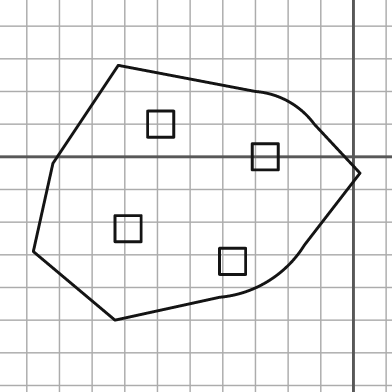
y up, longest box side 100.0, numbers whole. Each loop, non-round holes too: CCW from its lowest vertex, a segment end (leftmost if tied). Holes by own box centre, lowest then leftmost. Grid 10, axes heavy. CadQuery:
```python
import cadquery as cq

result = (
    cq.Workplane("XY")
    .moveTo(-73.0, -50.0)
    .lineTo(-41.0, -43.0)
    .threePointArc((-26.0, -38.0), (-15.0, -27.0))
    .lineTo(2.0, -5.0)
    .lineTo(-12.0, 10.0)
    .threePointArc((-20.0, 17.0), (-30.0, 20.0))
    .lineTo(-72.0, 28.0)
    .lineTo(-92.0, -2.0)
    .lineTo(-98.0, -29.0)
    .close()
    .moveTo(-41.0, -36.0)
    .lineTo(-33.0, -36.0)
    .lineTo(-33.0, -28.0)
    .lineTo(-41.0, -28.0)
    .close()
    .moveTo(-73.0, -26.0)
    .lineTo(-65.0, -26.0)
    .lineTo(-65.0, -18.0)
    .lineTo(-73.0, -18.0)
    .close()
    .moveTo(-31.0, -4.0)
    .lineTo(-23.0, -4.0)
    .lineTo(-23.0, 4.0)
    .lineTo(-31.0, 4.0)
    .close()
    .moveTo(-63.0, 6.0)
    .lineTo(-55.0, 6.0)
    .lineTo(-55.0, 14.0)
    .lineTo(-63.0, 14.0)
    .close()
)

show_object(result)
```